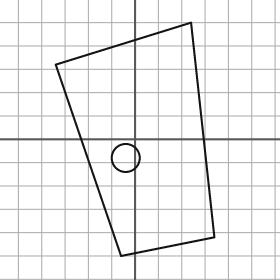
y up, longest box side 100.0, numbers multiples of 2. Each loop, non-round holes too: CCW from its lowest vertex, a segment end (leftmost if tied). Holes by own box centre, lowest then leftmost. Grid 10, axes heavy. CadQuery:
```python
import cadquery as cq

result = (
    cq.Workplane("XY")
    .moveTo(-6.0, -50.0)
    .lineTo(34.0, -42.0)
    .lineTo(24.0, 50.0)
    .lineTo(-34.0, 32.0)
    .close()
    .moveTo(-4.0, -8.0)
    .circle(6.0)
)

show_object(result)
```